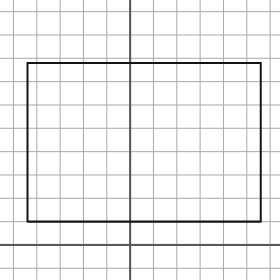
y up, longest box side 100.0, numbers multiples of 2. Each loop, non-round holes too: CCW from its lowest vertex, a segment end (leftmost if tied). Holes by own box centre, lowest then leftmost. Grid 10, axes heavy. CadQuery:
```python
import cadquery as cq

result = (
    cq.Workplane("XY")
    .moveTo(-44.0, 10.0)
    .lineTo(56.0, 10.0)
    .lineTo(56.0, 78.0)
    .lineTo(-44.0, 78.0)
    .close()
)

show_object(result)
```